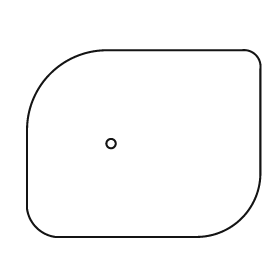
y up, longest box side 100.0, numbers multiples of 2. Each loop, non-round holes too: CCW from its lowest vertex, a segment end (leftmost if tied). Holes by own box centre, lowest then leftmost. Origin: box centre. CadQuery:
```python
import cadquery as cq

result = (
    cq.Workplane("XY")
    .moveTo(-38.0, -40.0)
    .lineTo(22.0, -40.0)
    .threePointArc((42.0, -32.0), (50.0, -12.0))
    .lineTo(50.0, 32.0)
    .threePointArc((48.0, 38.0), (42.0, 40.0))
    .lineTo(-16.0, 40.0)
    .threePointArc((-40.0, 30.0), (-50.0, 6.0))
    .lineTo(-50.0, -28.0)
    .threePointArc((-46.0, -36.0), (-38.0, -40.0))
    .close()
    .moveTo(-14.0, 0.0)
    .circle(2.0)
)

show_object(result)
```